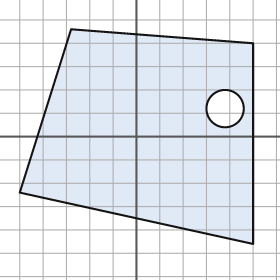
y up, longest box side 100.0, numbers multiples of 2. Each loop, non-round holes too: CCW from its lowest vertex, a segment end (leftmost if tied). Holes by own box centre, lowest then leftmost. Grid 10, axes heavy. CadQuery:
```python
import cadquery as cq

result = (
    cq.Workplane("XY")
    .moveTo(50.0, -46.0)
    .lineTo(50.0, 40.0)
    .lineTo(-28.0, 46.0)
    .lineTo(-50.0, -24.0)
    .close()
    .moveTo(38.0, 12.0)
    .circle(8.0)
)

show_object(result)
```